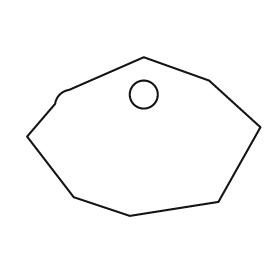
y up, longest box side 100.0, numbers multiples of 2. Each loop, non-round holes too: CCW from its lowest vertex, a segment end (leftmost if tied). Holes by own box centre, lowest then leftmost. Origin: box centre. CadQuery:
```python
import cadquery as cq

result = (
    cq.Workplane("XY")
    .moveTo(-6.0, -34.0)
    .lineTo(32.0, -28.0)
    .lineTo(50.0, 4.0)
    .lineTo(28.0, 24.0)
    .lineTo(0.0, 34.0)
    .lineTo(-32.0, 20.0)
    .threePointArc((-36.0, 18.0), (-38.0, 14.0))
    .lineTo(-50.0, 0.0)
    .lineTo(-30.0, -26.0)
    .close()
    .moveTo(0.0, 18.0)
    .circle(6.0)
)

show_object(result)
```